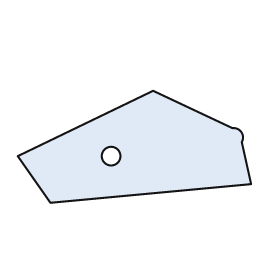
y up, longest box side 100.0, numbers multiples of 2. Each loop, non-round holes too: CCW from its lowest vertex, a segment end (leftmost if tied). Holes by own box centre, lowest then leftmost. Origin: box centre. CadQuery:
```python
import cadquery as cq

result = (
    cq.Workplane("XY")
    .moveTo(-36.0, -24.0)
    .lineTo(50.0, -16.0)
    .lineTo(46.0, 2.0)
    .threePointArc((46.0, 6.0), (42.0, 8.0))
    .lineTo(8.0, 24.0)
    .lineTo(-50.0, -4.0)
    .close()
    .moveTo(-10.0, -4.0)
    .circle(4.0)
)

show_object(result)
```